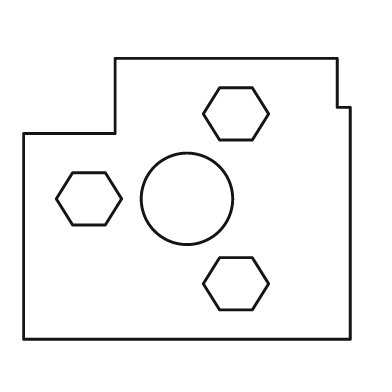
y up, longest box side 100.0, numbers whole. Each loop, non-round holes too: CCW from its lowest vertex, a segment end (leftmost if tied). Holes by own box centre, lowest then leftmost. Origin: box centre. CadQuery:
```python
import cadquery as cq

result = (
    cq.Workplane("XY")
    .moveTo(-50.0, -43.0)
    .lineTo(50.0, -43.0)
    .lineTo(50.0, 28.0)
    .lineTo(46.0, 28.0)
    .lineTo(46.0, 43.0)
    .lineTo(-22.0, 43.0)
    .lineTo(-22.0, 20.0)
    .lineTo(-50.0, 20.0)
    .close()
    .moveTo(10.0, -34.0)
    .lineTo(20.0, -34.0)
    .lineTo(25.0, -26.0)
    .lineTo(20.0, -18.0)
    .lineTo(10.0, -18.0)
    .lineTo(5.0, -26.0)
    .close()
    .moveTo(-35.0, -8.0)
    .lineTo(-25.0, -8.0)
    .lineTo(-20.0, 0.0)
    .lineTo(-25.0, 8.0)
    .lineTo(-35.0, 8.0)
    .lineTo(-40.0, 0.0)
    .close()
    .moveTo(0.0, 0.0)
    .circle(14.0)
    .moveTo(10.0, 18.0)
    .lineTo(20.0, 18.0)
    .lineTo(25.0, 26.0)
    .lineTo(20.0, 34.0)
    .lineTo(10.0, 34.0)
    .lineTo(5.0, 26.0)
    .close()
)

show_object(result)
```